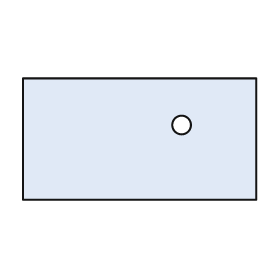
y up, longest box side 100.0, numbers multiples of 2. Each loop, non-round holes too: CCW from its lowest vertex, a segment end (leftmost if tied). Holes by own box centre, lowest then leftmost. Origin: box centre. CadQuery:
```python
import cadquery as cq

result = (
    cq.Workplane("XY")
    .moveTo(-50.0, -26.0)
    .lineTo(50.0, -26.0)
    .lineTo(50.0, 26.0)
    .lineTo(-50.0, 26.0)
    .close()
    .moveTo(18.0, 6.0)
    .circle(4.0)
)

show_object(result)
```